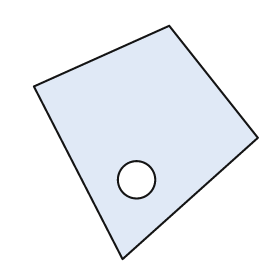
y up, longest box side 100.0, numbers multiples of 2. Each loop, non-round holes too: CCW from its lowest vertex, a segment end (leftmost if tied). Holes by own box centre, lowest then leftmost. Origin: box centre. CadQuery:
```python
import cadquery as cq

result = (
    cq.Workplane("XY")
    .moveTo(-10.0, -50.0)
    .lineTo(48.0, 2.0)
    .lineTo(10.0, 50.0)
    .lineTo(-48.0, 24.0)
    .close()
    .moveTo(-4.0, -16.0)
    .circle(8.0)
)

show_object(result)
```